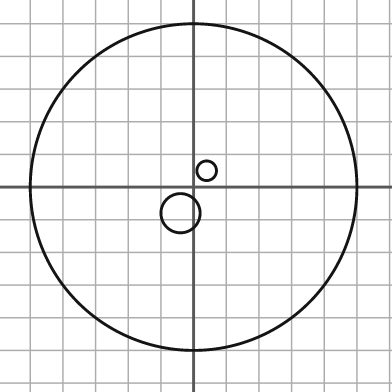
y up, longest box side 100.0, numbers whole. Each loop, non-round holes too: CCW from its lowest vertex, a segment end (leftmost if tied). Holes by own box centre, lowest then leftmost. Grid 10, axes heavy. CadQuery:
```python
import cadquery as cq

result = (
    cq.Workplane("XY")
    .moveTo(0.0, 0.0)
    .circle(50.0)
    .moveTo(-4.0, -8.0)
    .circle(6.0)
    .moveTo(4.0, 5.0)
    .circle(3.0)
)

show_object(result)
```